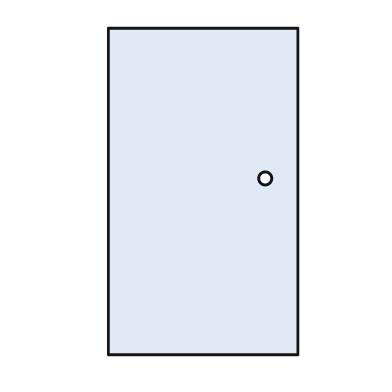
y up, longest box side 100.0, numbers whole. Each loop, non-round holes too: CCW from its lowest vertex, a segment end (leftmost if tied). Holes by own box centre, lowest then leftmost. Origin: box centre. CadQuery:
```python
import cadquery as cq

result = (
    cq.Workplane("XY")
    .moveTo(-29.0, -50.0)
    .lineTo(29.0, -50.0)
    .lineTo(29.0, 50.0)
    .lineTo(-29.0, 50.0)
    .close()
    .moveTo(19.0, 4.0)
    .circle(2.0)
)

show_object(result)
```